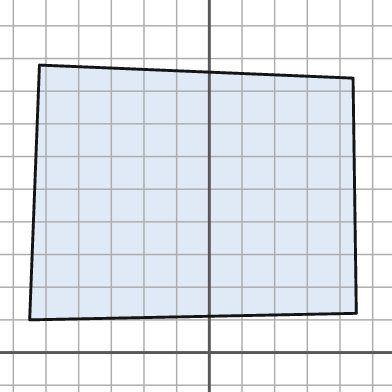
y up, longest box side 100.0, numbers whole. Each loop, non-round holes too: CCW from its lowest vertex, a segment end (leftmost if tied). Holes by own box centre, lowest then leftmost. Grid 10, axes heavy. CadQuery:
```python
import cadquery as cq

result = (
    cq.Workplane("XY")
    .moveTo(-55.0, 10.0)
    .lineTo(45.0, 12.0)
    .lineTo(44.0, 84.0)
    .lineTo(-52.0, 88.0)
    .close()
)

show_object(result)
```